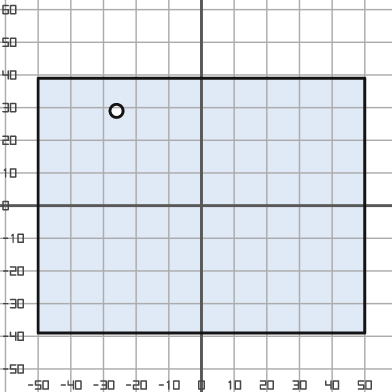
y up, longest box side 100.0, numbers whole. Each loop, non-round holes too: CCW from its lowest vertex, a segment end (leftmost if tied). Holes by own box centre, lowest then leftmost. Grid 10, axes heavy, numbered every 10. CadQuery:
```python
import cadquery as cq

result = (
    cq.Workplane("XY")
    .moveTo(-50.0, -39.0)
    .lineTo(50.0, -39.0)
    .lineTo(50.0, 39.0)
    .lineTo(-50.0, 39.0)
    .close()
    .moveTo(-26.0, 29.0)
    .circle(2.0)
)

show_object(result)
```